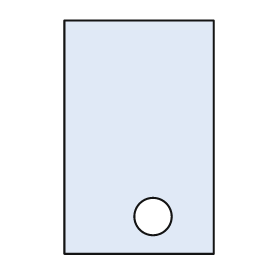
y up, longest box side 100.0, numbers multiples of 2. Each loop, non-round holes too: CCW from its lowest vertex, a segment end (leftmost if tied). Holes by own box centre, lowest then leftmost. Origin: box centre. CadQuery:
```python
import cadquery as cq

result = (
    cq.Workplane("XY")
    .moveTo(-32.0, -50.0)
    .lineTo(32.0, -50.0)
    .lineTo(32.0, 50.0)
    .lineTo(-32.0, 50.0)
    .close()
    .moveTo(6.0, -34.0)
    .circle(8.0)
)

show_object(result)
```